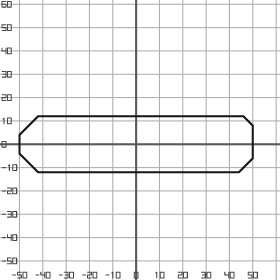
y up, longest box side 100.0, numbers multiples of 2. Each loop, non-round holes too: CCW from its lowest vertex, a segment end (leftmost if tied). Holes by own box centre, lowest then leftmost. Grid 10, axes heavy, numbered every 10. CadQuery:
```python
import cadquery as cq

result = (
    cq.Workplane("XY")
    .moveTo(-42.0, -12.0)
    .lineTo(44.0, -12.0)
    .lineTo(50.0, -6.0)
    .lineTo(50.0, 8.0)
    .lineTo(46.0, 12.0)
    .lineTo(-42.0, 12.0)
    .lineTo(-50.0, 4.0)
    .lineTo(-50.0, -4.0)
    .close()
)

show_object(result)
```